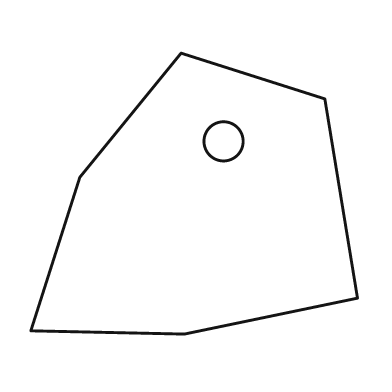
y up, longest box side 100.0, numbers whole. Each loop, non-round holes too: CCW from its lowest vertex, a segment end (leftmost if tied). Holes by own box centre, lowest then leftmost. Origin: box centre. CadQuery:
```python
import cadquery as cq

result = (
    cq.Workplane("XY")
    .moveTo(-3.0, -43.0)
    .lineTo(50.0, -32.0)
    .lineTo(40.0, 29.0)
    .lineTo(-4.0, 43.0)
    .lineTo(-35.0, 5.0)
    .lineTo(-50.0, -42.0)
    .close()
    .moveTo(9.0, 16.0)
    .circle(6.0)
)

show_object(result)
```